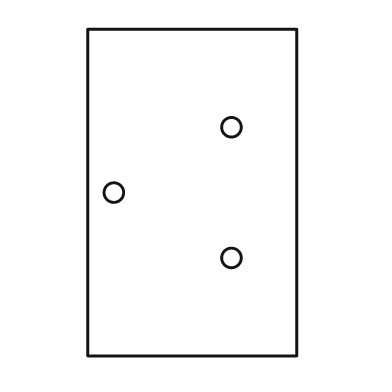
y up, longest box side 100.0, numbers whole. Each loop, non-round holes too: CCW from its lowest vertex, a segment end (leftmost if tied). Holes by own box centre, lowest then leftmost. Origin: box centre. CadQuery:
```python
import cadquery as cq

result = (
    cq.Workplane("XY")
    .moveTo(-32.0, -50.0)
    .lineTo(32.0, -50.0)
    .lineTo(32.0, 50.0)
    .lineTo(-32.0, 50.0)
    .close()
    .moveTo(12.0, -20.0)
    .circle(3.0)
    .moveTo(-24.0, 0.0)
    .circle(3.0)
    .moveTo(12.0, 20.0)
    .circle(3.0)
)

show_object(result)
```